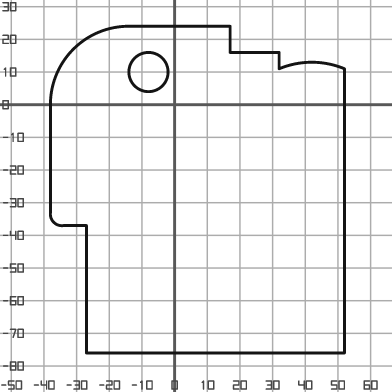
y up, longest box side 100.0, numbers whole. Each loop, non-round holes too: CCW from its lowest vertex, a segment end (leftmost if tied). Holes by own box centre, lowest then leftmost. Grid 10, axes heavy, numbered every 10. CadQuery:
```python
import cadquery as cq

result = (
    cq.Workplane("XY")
    .moveTo(-27.0, -76.0)
    .lineTo(52.0, -76.0)
    .lineTo(52.0, 11.0)
    .threePointArc((42.0, 13.0), (32.0, 11.0))
    .lineTo(32.0, 16.0)
    .lineTo(17.0, 16.0)
    .lineTo(17.0, 24.0)
    .lineTo(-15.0, 24.0)
    .threePointArc((-31.0, 17.0), (-38.0, 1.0))
    .lineTo(-38.0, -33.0)
    .threePointArc((-37.0, -36.0), (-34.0, -37.0))
    .lineTo(-27.0, -37.0)
    .close()
    .moveTo(-8.0, 10.0)
    .circle(6.0)
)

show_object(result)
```